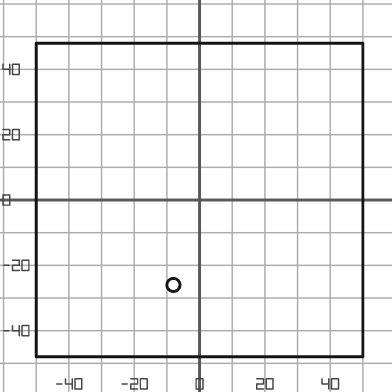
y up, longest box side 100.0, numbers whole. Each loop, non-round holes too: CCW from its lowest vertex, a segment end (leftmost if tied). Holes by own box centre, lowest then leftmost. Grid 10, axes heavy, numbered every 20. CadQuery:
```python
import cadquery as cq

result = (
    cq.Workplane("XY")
    .moveTo(-50.0, -48.0)
    .lineTo(50.0, -48.0)
    .lineTo(50.0, 48.0)
    .lineTo(-50.0, 48.0)
    .close()
    .moveTo(-8.0, -26.0)
    .circle(2.0)
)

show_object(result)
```